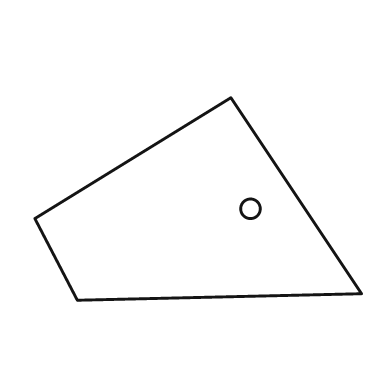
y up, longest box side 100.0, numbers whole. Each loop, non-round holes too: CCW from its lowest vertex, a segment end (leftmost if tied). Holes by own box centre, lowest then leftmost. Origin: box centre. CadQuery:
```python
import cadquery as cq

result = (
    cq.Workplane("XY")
    .moveTo(-37.0, -31.0)
    .lineTo(50.0, -29.0)
    .lineTo(10.0, 31.0)
    .lineTo(-50.0, -6.0)
    .close()
    .moveTo(16.0, -3.0)
    .circle(3.0)
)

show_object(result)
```